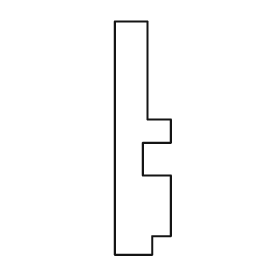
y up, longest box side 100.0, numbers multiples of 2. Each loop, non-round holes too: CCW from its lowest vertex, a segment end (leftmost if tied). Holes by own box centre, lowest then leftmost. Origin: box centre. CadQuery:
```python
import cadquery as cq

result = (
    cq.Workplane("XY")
    .moveTo(-12.0, -50.0)
    .lineTo(4.0, -50.0)
    .lineTo(4.0, -42.0)
    .lineTo(12.0, -42.0)
    .lineTo(12.0, -16.0)
    .lineTo(0.0, -16.0)
    .lineTo(0.0, -2.0)
    .lineTo(12.0, -2.0)
    .lineTo(12.0, 8.0)
    .lineTo(2.0, 8.0)
    .lineTo(2.0, 50.0)
    .lineTo(-12.0, 50.0)
    .close()
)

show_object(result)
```